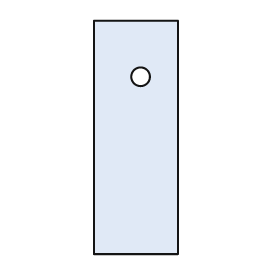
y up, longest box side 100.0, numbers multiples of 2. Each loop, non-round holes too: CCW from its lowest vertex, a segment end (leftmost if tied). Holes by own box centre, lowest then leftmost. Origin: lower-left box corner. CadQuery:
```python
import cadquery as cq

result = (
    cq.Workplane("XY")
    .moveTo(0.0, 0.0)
    .lineTo(36.0, 0.0)
    .lineTo(36.0, 100.0)
    .lineTo(0.0, 100.0)
    .close()
    .moveTo(20.0, 76.0)
    .circle(4.0)
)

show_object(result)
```